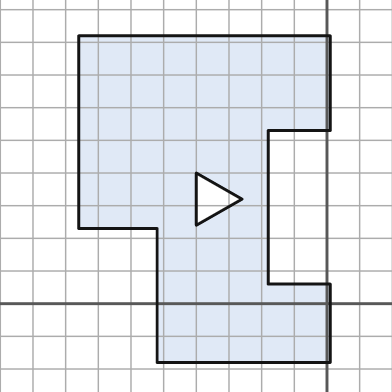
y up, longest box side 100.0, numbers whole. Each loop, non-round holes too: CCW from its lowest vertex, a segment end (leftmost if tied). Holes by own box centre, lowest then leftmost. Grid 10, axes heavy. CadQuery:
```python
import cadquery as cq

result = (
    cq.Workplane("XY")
    .moveTo(-52.0, -18.0)
    .lineTo(1.0, -18.0)
    .lineTo(1.0, 6.0)
    .lineTo(-18.0, 6.0)
    .lineTo(-18.0, 53.0)
    .lineTo(1.0, 53.0)
    .lineTo(1.0, 82.0)
    .lineTo(-76.0, 82.0)
    .lineTo(-76.0, 23.0)
    .lineTo(-52.0, 23.0)
    .close()
    .moveTo(-40.0, 24.0)
    .lineTo(-26.0, 32.0)
    .lineTo(-40.0, 40.0)
    .close()
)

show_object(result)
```